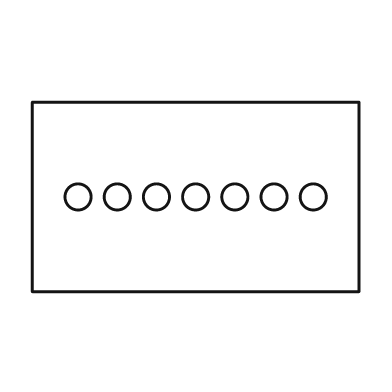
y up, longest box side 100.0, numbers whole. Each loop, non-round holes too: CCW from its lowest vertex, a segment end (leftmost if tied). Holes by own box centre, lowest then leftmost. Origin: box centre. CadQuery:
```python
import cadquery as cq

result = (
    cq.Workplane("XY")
    .moveTo(-50.0, -29.0)
    .lineTo(50.0, -29.0)
    .lineTo(50.0, 29.0)
    .lineTo(-50.0, 29.0)
    .close()
    .moveTo(-36.0, 0.0)
    .circle(4.0)
    .moveTo(-24.0, 0.0)
    .circle(4.0)
    .moveTo(-12.0, 0.0)
    .circle(4.0)
    .moveTo(0.0, 0.0)
    .circle(4.0)
    .moveTo(12.0, 0.0)
    .circle(4.0)
    .moveTo(24.0, 0.0)
    .circle(4.0)
    .moveTo(36.0, 0.0)
    .circle(4.0)
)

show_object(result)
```